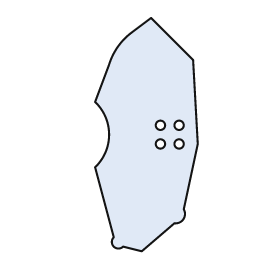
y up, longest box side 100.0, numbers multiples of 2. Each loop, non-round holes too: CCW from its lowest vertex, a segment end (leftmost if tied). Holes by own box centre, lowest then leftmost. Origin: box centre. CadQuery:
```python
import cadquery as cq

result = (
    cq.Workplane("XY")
    .moveTo(-2.0, -50.0)
    .lineTo(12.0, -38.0)
    .threePointArc((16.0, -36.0), (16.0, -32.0))
    .lineTo(22.0, -4.0)
    .lineTo(20.0, 32.0)
    .lineTo(2.0, 50.0)
    .lineTo(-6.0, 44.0)
    .threePointArc((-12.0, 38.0), (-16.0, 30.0))
    .lineTo(-22.0, 14.0)
    .threePointArc((-16.0, 0.0), (-22.0, -14.0))
    .lineTo(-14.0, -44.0)
    .threePointArc((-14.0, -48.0), (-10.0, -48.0))
    .close()
    .moveTo(6.0, -4.0)
    .circle(2.0)
    .moveTo(14.0, -4.0)
    .circle(2.0)
    .moveTo(6.0, 4.0)
    .circle(2.0)
    .moveTo(14.0, 4.0)
    .circle(2.0)
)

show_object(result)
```